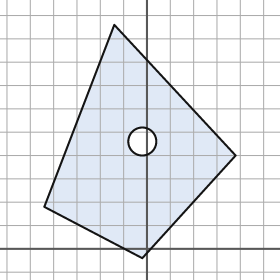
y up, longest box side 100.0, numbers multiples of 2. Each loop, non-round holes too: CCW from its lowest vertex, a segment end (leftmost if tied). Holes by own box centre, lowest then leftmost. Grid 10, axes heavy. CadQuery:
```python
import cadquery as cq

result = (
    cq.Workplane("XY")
    .moveTo(-2.0, -4.0)
    .lineTo(38.0, 40.0)
    .lineTo(-14.0, 96.0)
    .lineTo(-44.0, 18.0)
    .close()
    .moveTo(-2.0, 46.0)
    .circle(6.0)
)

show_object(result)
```